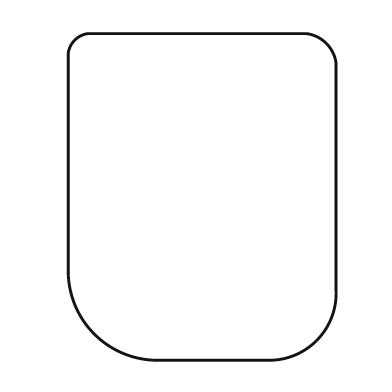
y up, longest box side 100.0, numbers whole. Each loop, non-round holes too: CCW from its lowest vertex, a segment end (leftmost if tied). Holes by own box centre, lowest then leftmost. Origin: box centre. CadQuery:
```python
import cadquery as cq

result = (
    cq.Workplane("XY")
    .moveTo(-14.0, -50.0)
    .lineTo(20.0, -50.0)
    .threePointArc((35.0, -44.0), (41.0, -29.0))
    .lineTo(41.0, 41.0)
    .threePointArc((38.0, 47.0), (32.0, 50.0))
    .lineTo(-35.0, 50.0)
    .threePointArc((-39.0, 48.0), (-41.0, 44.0))
    .lineTo(-41.0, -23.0)
    .threePointArc((-33.0, -42.0), (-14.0, -50.0))
    .close()
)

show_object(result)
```